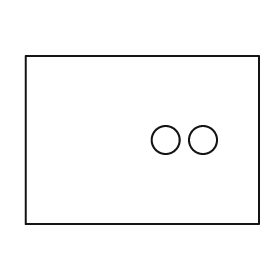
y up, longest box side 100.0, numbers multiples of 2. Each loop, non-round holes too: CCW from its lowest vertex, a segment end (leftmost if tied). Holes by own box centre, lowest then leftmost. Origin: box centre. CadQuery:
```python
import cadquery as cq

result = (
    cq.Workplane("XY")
    .moveTo(-50.0, -36.0)
    .lineTo(50.0, -36.0)
    .lineTo(50.0, 36.0)
    .lineTo(-50.0, 36.0)
    .close()
    .moveTo(10.0, 0.0)
    .circle(6.0)
    .moveTo(26.0, 0.0)
    .circle(6.0)
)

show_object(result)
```